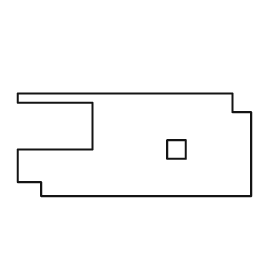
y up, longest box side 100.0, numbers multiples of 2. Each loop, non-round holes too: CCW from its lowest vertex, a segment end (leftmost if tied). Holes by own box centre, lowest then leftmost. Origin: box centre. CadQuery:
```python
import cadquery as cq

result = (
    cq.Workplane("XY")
    .moveTo(-40.0, -22.0)
    .lineTo(50.0, -22.0)
    .lineTo(50.0, 14.0)
    .lineTo(42.0, 14.0)
    .lineTo(42.0, 22.0)
    .lineTo(-50.0, 22.0)
    .lineTo(-50.0, 18.0)
    .lineTo(-18.0, 18.0)
    .lineTo(-18.0, -2.0)
    .lineTo(-50.0, -2.0)
    .lineTo(-50.0, -16.0)
    .lineTo(-40.0, -16.0)
    .close()
    .moveTo(14.0, -6.0)
    .lineTo(22.0, -6.0)
    .lineTo(22.0, 2.0)
    .lineTo(14.0, 2.0)
    .close()
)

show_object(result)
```